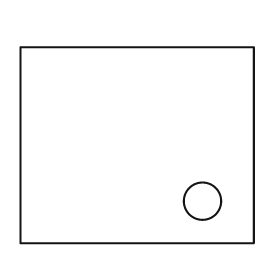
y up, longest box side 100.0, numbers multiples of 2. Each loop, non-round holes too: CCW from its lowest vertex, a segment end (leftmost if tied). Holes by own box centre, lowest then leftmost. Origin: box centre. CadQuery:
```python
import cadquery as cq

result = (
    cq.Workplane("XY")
    .moveTo(-50.0, -42.0)
    .lineTo(50.0, -42.0)
    .lineTo(50.0, 42.0)
    .lineTo(-50.0, 42.0)
    .close()
    .moveTo(28.0, -24.0)
    .circle(8.0)
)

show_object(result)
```